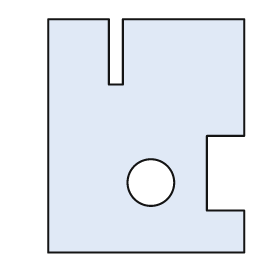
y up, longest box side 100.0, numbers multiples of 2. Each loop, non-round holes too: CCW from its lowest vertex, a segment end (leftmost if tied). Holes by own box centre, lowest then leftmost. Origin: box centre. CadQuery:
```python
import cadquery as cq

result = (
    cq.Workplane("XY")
    .moveTo(-42.0, -50.0)
    .lineTo(42.0, -50.0)
    .lineTo(42.0, -32.0)
    .lineTo(26.0, -32.0)
    .lineTo(26.0, 0.0)
    .lineTo(42.0, 0.0)
    .lineTo(42.0, 50.0)
    .lineTo(-10.0, 50.0)
    .lineTo(-10.0, 22.0)
    .lineTo(-16.0, 22.0)
    .lineTo(-16.0, 50.0)
    .lineTo(-42.0, 50.0)
    .close()
    .moveTo(2.0, -20.0)
    .circle(10.0)
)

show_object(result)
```